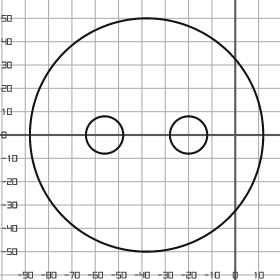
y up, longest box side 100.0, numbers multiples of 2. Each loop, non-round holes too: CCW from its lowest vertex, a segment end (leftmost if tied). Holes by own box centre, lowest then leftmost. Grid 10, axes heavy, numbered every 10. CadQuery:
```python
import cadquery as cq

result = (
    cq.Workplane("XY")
    .moveTo(-38.0, 0.0)
    .circle(50.0)
    .moveTo(-56.0, 0.0)
    .circle(8.0)
    .moveTo(-20.0, 0.0)
    .circle(8.0)
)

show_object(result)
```